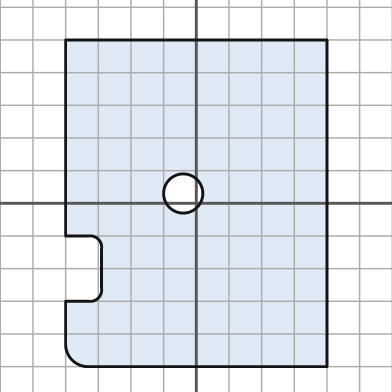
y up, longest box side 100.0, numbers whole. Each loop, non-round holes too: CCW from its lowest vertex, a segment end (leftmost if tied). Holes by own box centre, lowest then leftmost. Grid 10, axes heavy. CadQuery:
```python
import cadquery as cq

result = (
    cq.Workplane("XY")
    .moveTo(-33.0, -50.0)
    .lineTo(40.0, -50.0)
    .lineTo(40.0, 50.0)
    .lineTo(-40.0, 50.0)
    .lineTo(-40.0, -10.0)
    .lineTo(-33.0, -10.0)
    .threePointArc((-30.0, -11.0), (-29.0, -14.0))
    .lineTo(-29.0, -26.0)
    .threePointArc((-30.0, -29.0), (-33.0, -30.0))
    .lineTo(-40.0, -30.0)
    .lineTo(-40.0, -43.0)
    .threePointArc((-38.0, -48.0), (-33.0, -50.0))
    .close()
    .moveTo(-4.0, 3.0)
    .circle(6.0)
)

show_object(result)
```